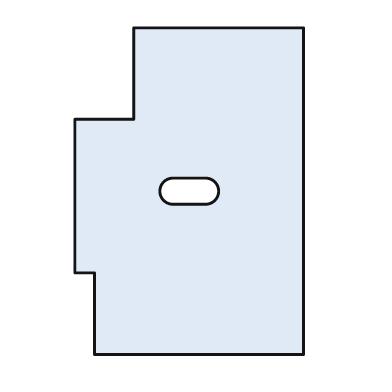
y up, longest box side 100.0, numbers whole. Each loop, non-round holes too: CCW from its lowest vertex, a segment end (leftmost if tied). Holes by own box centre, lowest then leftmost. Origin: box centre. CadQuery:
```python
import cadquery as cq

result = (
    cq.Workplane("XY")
    .moveTo(-29.0, -50.0)
    .lineTo(35.0, -50.0)
    .lineTo(35.0, 50.0)
    .lineTo(-17.0, 50.0)
    .lineTo(-17.0, 22.0)
    .lineTo(-35.0, 22.0)
    .lineTo(-35.0, -25.0)
    .lineTo(-29.0, -25.0)
    .close()
    .moveTo(-5.0, -4.0)
    .lineTo(5.0, -4.0)
    .threePointArc((9.0, 0.0), (5.0, 4.0))
    .lineTo(-5.0, 4.0)
    .threePointArc((-9.0, 0.0), (-5.0, -4.0))
    .close()
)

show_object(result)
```